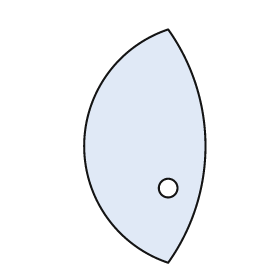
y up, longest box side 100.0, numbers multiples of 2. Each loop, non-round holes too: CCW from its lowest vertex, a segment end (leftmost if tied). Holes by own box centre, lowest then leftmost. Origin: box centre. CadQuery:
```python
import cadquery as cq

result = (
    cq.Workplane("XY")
    .moveTo(10.0, -50.0)
    .threePointArc((26.0, 0.0), (10.0, 50.0))
    .threePointArc((-26.0, 0.0), (10.0, -50.0))
    .close()
    .moveTo(10.0, -18.0)
    .circle(4.0)
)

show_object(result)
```